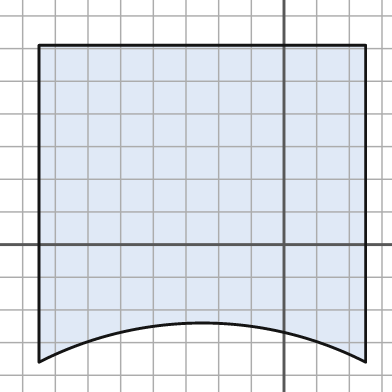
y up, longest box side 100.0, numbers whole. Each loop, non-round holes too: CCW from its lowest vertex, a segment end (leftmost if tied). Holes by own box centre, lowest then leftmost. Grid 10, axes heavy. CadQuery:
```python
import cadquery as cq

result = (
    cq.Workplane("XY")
    .moveTo(-75.0, -36.0)
    .threePointArc((-25.0, -24.0), (25.0, -36.0))
    .lineTo(25.0, 61.0)
    .lineTo(-75.0, 61.0)
    .close()
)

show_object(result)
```